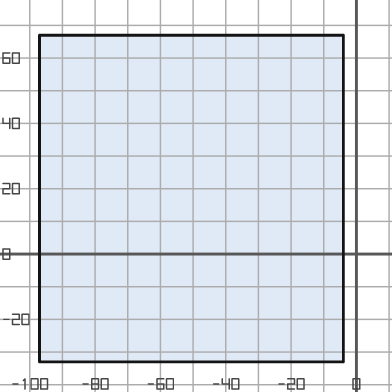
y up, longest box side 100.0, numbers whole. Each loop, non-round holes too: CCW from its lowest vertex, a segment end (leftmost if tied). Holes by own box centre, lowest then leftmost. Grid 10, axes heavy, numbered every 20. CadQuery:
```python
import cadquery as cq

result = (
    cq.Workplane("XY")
    .moveTo(-97.0, -33.0)
    .lineTo(-4.0, -33.0)
    .lineTo(-4.0, 67.0)
    .lineTo(-97.0, 67.0)
    .close()
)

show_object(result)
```